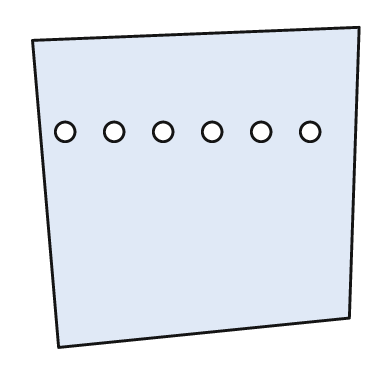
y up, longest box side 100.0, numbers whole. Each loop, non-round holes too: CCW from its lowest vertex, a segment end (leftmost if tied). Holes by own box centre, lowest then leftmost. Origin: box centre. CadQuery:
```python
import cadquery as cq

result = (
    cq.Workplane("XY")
    .moveTo(-42.0, -49.0)
    .lineTo(47.0, -40.0)
    .lineTo(50.0, 49.0)
    .lineTo(-50.0, 45.0)
    .close()
    .moveTo(-40.0, 17.0)
    .circle(3.0)
    .moveTo(-25.0, 17.0)
    .circle(3.0)
    .moveTo(-10.0, 17.0)
    .circle(3.0)
    .moveTo(5.0, 17.0)
    .circle(3.0)
    .moveTo(20.0, 17.0)
    .circle(3.0)
    .moveTo(35.0, 17.0)
    .circle(3.0)
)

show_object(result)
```